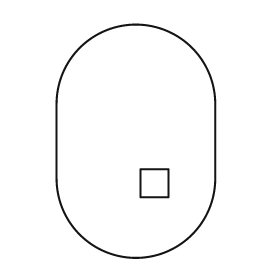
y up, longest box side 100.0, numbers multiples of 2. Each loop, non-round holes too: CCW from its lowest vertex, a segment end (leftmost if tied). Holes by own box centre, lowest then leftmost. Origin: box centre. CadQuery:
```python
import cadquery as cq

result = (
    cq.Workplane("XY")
    .moveTo(-34.0, -16.0)
    .threePointArc((0.0, -50.0), (34.0, -16.0))
    .lineTo(34.0, 16.0)
    .threePointArc((0.0, 50.0), (-34.0, 16.0))
    .close()
    .moveTo(2.0, -24.0)
    .lineTo(14.0, -24.0)
    .lineTo(14.0, -12.0)
    .lineTo(2.0, -12.0)
    .close()
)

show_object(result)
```